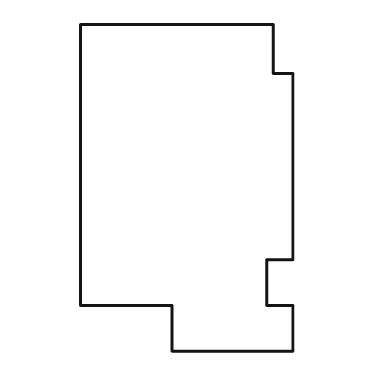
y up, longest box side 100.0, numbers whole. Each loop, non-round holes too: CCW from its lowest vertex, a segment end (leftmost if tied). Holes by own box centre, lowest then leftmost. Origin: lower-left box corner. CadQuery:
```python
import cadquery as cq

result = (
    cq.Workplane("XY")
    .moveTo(28.0, 0.0)
    .lineTo(65.0, 0.0)
    .lineTo(65.0, 14.0)
    .lineTo(57.0, 14.0)
    .lineTo(57.0, 28.0)
    .lineTo(65.0, 28.0)
    .lineTo(65.0, 85.0)
    .lineTo(59.0, 85.0)
    .lineTo(59.0, 100.0)
    .lineTo(0.0, 100.0)
    .lineTo(0.0, 14.0)
    .lineTo(28.0, 14.0)
    .close()
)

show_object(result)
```